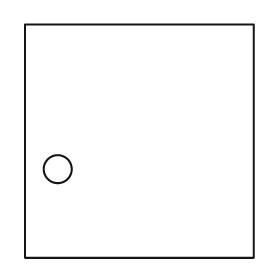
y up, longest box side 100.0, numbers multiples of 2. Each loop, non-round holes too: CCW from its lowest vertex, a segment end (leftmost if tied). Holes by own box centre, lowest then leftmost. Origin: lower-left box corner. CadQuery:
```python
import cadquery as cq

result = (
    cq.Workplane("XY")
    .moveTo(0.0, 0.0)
    .lineTo(98.0, 0.0)
    .lineTo(98.0, 100.0)
    .lineTo(0.0, 100.0)
    .close()
    .moveTo(14.0, 38.0)
    .circle(6.0)
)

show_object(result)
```